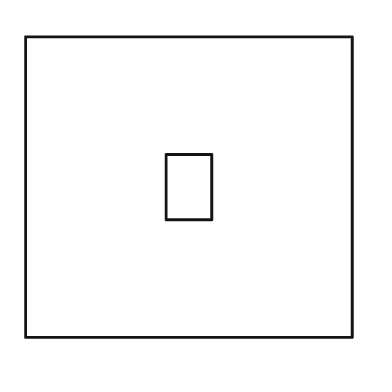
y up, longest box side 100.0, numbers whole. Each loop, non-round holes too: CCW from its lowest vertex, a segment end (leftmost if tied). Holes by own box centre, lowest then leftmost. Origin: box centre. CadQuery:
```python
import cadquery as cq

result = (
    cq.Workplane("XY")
    .moveTo(-50.0, -46.0)
    .lineTo(50.0, -46.0)
    .lineTo(50.0, 46.0)
    .lineTo(-50.0, 46.0)
    .close()
    .moveTo(-7.0, -10.0)
    .lineTo(7.0, -10.0)
    .lineTo(7.0, 10.0)
    .lineTo(-7.0, 10.0)
    .close()
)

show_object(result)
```